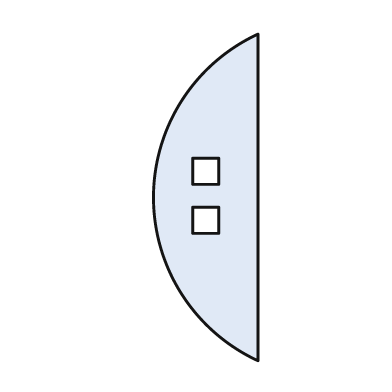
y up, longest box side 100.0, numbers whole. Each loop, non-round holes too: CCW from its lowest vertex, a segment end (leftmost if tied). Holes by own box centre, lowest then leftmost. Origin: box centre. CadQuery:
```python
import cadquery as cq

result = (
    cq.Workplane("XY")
    .moveTo(16.0, -50.0)
    .lineTo(16.0, 50.0)
    .threePointArc((-16.0, 0.0), (16.0, -50.0))
    .close()
    .moveTo(-4.0, -11.0)
    .lineTo(4.0, -11.0)
    .lineTo(4.0, -3.0)
    .lineTo(-4.0, -3.0)
    .close()
    .moveTo(-4.0, 4.0)
    .lineTo(4.0, 4.0)
    .lineTo(4.0, 12.0)
    .lineTo(-4.0, 12.0)
    .close()
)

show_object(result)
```